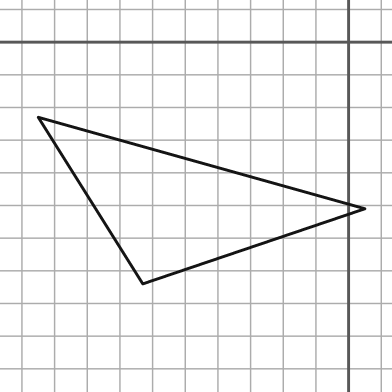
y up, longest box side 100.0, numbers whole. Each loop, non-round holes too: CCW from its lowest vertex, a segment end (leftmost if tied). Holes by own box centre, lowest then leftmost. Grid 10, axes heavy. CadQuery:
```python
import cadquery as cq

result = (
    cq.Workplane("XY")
    .moveTo(-63.0, -74.0)
    .lineTo(5.0, -51.0)
    .lineTo(-95.0, -23.0)
    .close()
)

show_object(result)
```